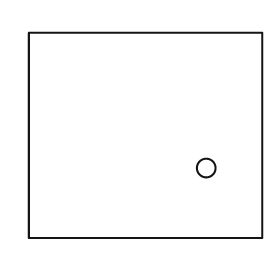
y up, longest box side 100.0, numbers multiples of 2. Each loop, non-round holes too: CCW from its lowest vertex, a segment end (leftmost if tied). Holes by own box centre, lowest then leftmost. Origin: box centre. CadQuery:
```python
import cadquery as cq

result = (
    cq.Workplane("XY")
    .moveTo(-50.0, -44.0)
    .lineTo(50.0, -44.0)
    .lineTo(50.0, 44.0)
    .lineTo(-50.0, 44.0)
    .close()
    .moveTo(26.0, -14.0)
    .circle(4.0)
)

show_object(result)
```